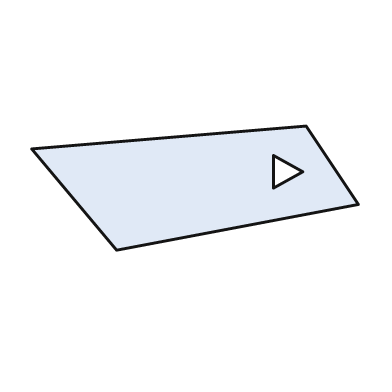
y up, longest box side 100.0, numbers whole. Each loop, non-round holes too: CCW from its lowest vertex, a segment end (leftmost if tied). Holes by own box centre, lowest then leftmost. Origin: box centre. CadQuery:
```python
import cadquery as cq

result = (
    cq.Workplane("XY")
    .moveTo(-24.0, -19.0)
    .lineTo(50.0, -5.0)
    .lineTo(34.0, 19.0)
    .lineTo(-50.0, 12.0)
    .close()
    .moveTo(24.0, 0.0)
    .lineTo(33.0, 5.0)
    .lineTo(24.0, 10.0)
    .close()
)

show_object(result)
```